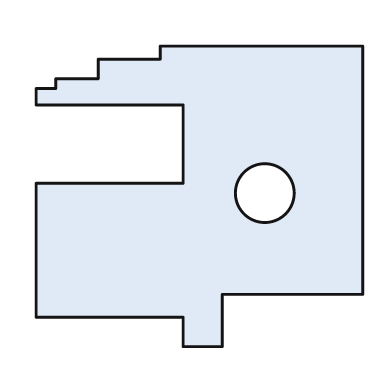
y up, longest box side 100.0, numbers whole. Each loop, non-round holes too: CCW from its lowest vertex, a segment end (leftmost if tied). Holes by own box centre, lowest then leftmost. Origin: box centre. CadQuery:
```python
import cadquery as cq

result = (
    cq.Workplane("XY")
    .moveTo(-5.0, -46.0)
    .lineTo(7.0, -46.0)
    .lineTo(7.0, -30.0)
    .lineTo(50.0, -30.0)
    .lineTo(50.0, 46.0)
    .lineTo(-12.0, 46.0)
    .lineTo(-12.0, 42.0)
    .lineTo(-31.0, 42.0)
    .lineTo(-31.0, 36.0)
    .lineTo(-44.0, 36.0)
    .lineTo(-44.0, 33.0)
    .lineTo(-50.0, 33.0)
    .lineTo(-50.0, 28.0)
    .lineTo(-5.0, 28.0)
    .lineTo(-5.0, 4.0)
    .lineTo(-50.0, 4.0)
    .lineTo(-50.0, -37.0)
    .lineTo(-5.0, -37.0)
    .close()
    .moveTo(20.0, 1.0)
    .circle(9.0)
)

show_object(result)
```